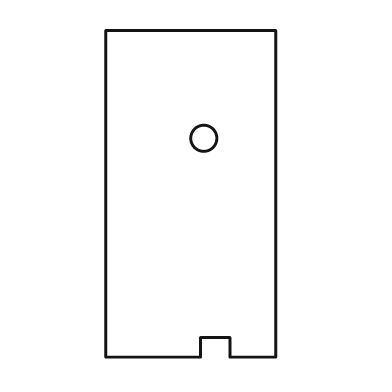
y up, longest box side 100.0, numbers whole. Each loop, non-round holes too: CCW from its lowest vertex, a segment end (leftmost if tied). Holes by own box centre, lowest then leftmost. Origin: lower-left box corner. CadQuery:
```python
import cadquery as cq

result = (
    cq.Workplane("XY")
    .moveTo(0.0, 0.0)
    .lineTo(29.0, 0.0)
    .lineTo(29.0, 6.0)
    .lineTo(38.0, 6.0)
    .lineTo(38.0, 0.0)
    .lineTo(52.0, 0.0)
    .lineTo(52.0, 100.0)
    .lineTo(0.0, 100.0)
    .close()
    .moveTo(30.0, 67.0)
    .circle(4.0)
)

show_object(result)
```